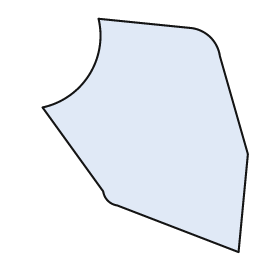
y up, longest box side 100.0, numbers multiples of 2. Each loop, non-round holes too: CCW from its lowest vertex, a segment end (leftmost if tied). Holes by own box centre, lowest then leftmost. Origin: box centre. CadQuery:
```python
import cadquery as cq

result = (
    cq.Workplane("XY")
    .moveTo(40.0, -50.0)
    .lineTo(44.0, -8.0)
    .lineTo(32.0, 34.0)
    .threePointArc((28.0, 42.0), (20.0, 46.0))
    .lineTo(-20.0, 50.0)
    .threePointArc((-24.0, 26.0), (-44.0, 12.0))
    .lineTo(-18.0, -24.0)
    .threePointArc((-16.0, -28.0), (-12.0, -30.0))
    .close()
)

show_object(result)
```